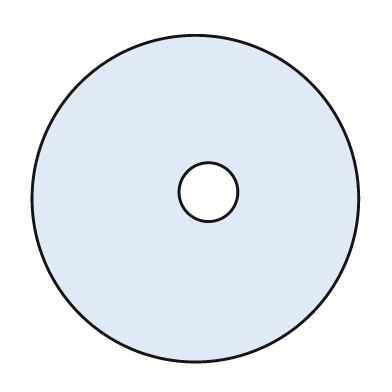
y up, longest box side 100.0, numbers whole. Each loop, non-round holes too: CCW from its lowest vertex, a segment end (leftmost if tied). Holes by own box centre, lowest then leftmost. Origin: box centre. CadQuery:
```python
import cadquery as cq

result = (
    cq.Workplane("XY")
    .moveTo(0.0, 0.0)
    .circle(50.0)
    .moveTo(4.0, 2.0)
    .circle(9.0)
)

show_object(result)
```